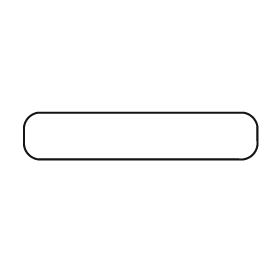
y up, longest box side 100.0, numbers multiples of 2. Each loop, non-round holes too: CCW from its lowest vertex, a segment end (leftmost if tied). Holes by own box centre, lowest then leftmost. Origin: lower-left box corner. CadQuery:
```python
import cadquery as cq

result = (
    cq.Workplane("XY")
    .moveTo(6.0, 0.0)
    .lineTo(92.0, 0.0)
    .threePointArc((98.0, 2.0), (100.0, 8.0))
    .lineTo(100.0, 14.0)
    .threePointArc((98.0, 18.0), (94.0, 20.0))
    .lineTo(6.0, 20.0)
    .threePointArc((2.0, 18.0), (0.0, 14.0))
    .lineTo(0.0, 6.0)
    .threePointArc((2.0, 2.0), (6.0, 0.0))
    .close()
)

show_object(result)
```